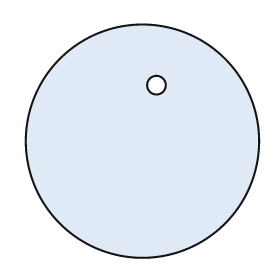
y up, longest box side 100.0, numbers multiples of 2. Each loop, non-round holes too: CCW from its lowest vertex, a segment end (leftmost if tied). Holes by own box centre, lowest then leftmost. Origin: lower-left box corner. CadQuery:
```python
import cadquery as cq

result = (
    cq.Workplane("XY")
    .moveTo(50.0, 50.0)
    .circle(50.0)
    .moveTo(56.0, 74.0)
    .circle(4.0)
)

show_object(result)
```